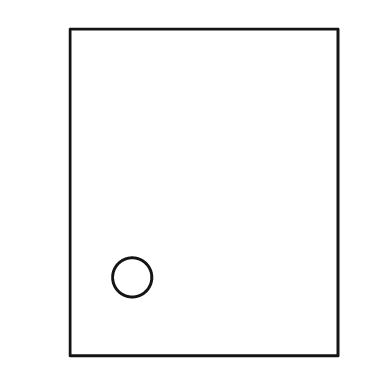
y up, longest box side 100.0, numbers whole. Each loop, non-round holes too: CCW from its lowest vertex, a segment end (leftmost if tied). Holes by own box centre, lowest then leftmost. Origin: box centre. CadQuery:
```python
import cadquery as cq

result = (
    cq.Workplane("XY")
    .moveTo(-41.0, -50.0)
    .lineTo(41.0, -50.0)
    .lineTo(41.0, 50.0)
    .lineTo(-41.0, 50.0)
    .close()
    .moveTo(-22.0, -26.0)
    .circle(6.0)
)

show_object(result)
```